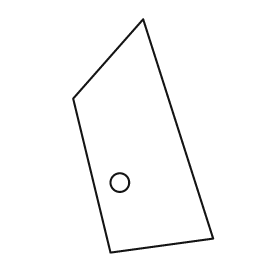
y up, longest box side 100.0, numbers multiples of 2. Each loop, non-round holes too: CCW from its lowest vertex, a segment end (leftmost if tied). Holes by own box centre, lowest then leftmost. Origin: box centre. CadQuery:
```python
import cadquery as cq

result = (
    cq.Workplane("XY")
    .moveTo(-14.0, -50.0)
    .lineTo(30.0, -44.0)
    .lineTo(0.0, 50.0)
    .lineTo(-30.0, 16.0)
    .close()
    .moveTo(-10.0, -20.0)
    .circle(4.0)
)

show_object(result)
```